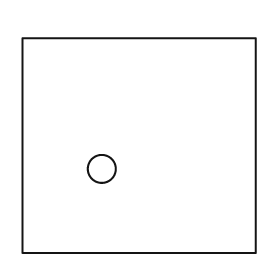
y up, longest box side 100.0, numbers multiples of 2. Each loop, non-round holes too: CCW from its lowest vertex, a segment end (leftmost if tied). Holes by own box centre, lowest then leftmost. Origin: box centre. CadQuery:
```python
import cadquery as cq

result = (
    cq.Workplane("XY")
    .moveTo(-50.0, -46.0)
    .lineTo(50.0, -46.0)
    .lineTo(50.0, 46.0)
    .lineTo(-50.0, 46.0)
    .close()
    .moveTo(-16.0, -10.0)
    .circle(6.0)
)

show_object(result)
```